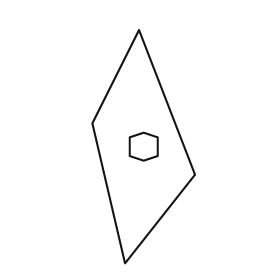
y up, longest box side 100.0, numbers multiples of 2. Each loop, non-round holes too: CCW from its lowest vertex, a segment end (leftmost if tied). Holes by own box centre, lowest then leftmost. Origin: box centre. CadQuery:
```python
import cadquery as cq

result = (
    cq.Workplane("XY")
    .moveTo(-8.0, -50.0)
    .lineTo(22.0, -12.0)
    .lineTo(-2.0, 50.0)
    .lineTo(-22.0, 10.0)
    .close()
    .moveTo(0.0, -6.0)
    .lineTo(6.0, -4.0)
    .lineTo(6.0, 4.0)
    .lineTo(0.0, 6.0)
    .lineTo(-6.0, 4.0)
    .lineTo(-6.0, -4.0)
    .close()
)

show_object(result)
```